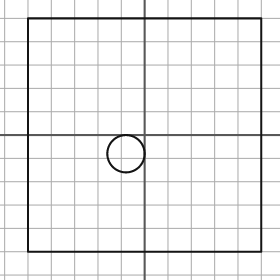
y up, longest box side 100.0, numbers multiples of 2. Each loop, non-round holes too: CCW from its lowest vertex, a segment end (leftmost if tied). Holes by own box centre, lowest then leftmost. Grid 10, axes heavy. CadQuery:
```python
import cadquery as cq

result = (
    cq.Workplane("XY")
    .moveTo(-50.0, -50.0)
    .lineTo(50.0, -50.0)
    .lineTo(50.0, 50.0)
    .lineTo(-50.0, 50.0)
    .close()
    .moveTo(-8.0, -8.0)
    .circle(8.0)
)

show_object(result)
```